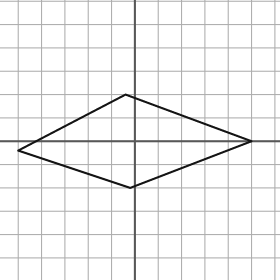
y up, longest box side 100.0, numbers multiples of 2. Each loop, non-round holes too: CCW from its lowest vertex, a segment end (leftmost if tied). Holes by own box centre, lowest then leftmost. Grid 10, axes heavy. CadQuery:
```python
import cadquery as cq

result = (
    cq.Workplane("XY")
    .moveTo(-2.0, -20.0)
    .lineTo(50.0, 0.0)
    .lineTo(-4.0, 20.0)
    .lineTo(-50.0, -4.0)
    .close()
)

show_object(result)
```